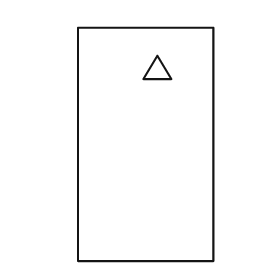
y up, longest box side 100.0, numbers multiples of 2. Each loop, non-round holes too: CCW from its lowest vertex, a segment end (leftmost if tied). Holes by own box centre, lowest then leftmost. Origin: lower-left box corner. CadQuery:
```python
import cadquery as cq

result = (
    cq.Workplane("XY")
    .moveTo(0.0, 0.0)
    .lineTo(58.0, 0.0)
    .lineTo(58.0, 100.0)
    .lineTo(0.0, 100.0)
    .close()
    .moveTo(28.0, 78.0)
    .lineTo(40.0, 78.0)
    .lineTo(34.0, 88.0)
    .close()
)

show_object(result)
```